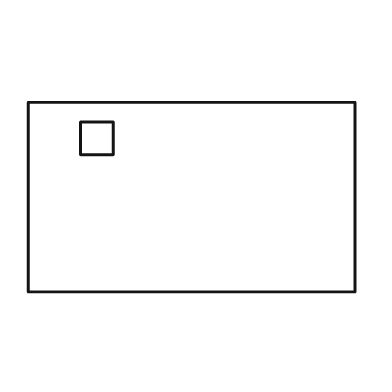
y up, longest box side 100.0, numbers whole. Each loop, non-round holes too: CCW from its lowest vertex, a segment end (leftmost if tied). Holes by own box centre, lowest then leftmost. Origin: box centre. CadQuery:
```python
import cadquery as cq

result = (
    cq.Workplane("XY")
    .moveTo(-50.0, -29.0)
    .lineTo(50.0, -29.0)
    .lineTo(50.0, 29.0)
    .lineTo(-50.0, 29.0)
    .close()
    .moveTo(-34.0, 13.0)
    .lineTo(-24.0, 13.0)
    .lineTo(-24.0, 23.0)
    .lineTo(-34.0, 23.0)
    .close()
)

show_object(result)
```